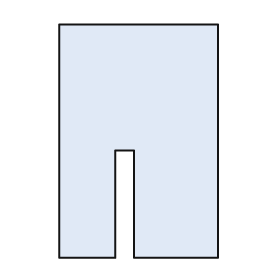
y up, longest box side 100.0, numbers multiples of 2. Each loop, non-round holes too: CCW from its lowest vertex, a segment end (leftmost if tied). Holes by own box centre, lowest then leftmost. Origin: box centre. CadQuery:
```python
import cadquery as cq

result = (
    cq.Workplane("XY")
    .moveTo(-34.0, -50.0)
    .lineTo(-10.0, -50.0)
    .lineTo(-10.0, -4.0)
    .lineTo(-2.0, -4.0)
    .lineTo(-2.0, -50.0)
    .lineTo(34.0, -50.0)
    .lineTo(34.0, 50.0)
    .lineTo(-34.0, 50.0)
    .close()
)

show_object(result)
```